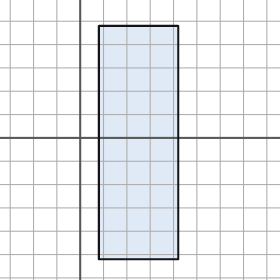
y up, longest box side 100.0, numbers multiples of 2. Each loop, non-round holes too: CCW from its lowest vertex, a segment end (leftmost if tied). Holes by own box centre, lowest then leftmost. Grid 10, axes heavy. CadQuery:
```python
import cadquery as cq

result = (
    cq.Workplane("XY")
    .moveTo(8.0, -52.0)
    .lineTo(42.0, -52.0)
    .lineTo(42.0, 48.0)
    .lineTo(8.0, 48.0)
    .close()
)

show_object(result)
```